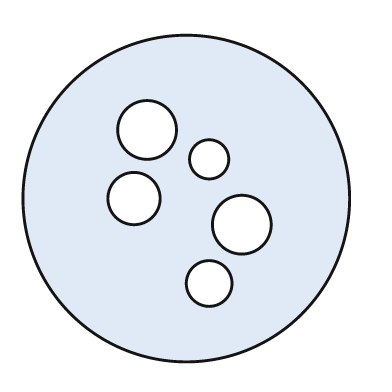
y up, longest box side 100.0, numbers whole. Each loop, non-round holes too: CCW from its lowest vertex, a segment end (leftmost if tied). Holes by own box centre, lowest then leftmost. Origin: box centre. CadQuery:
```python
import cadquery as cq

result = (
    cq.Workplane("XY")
    .moveTo(0.0, 0.0)
    .circle(50.0)
    .moveTo(7.0, -26.0)
    .circle(7.0)
    .moveTo(17.0, -8.0)
    .circle(9.0)
    .moveTo(-16.0, 0.0)
    .circle(8.0)
    .moveTo(7.0, 12.0)
    .circle(6.0)
    .moveTo(-12.0, 21.0)
    .circle(9.0)
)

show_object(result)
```